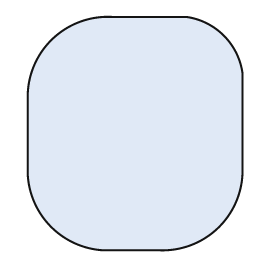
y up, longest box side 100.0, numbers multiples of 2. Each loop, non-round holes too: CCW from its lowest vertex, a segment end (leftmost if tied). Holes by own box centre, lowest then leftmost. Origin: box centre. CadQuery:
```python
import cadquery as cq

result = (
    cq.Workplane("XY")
    .moveTo(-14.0, -50.0)
    .lineTo(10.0, -50.0)
    .threePointArc((36.0, -40.0), (46.0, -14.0))
    .lineTo(46.0, 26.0)
    .threePointArc((38.0, 42.0), (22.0, 50.0))
    .lineTo(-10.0, 50.0)
    .threePointArc((-36.0, 40.0), (-46.0, 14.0))
    .lineTo(-46.0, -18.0)
    .threePointArc((-36.0, -40.0), (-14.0, -50.0))
    .close()
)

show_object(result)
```